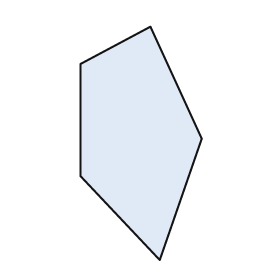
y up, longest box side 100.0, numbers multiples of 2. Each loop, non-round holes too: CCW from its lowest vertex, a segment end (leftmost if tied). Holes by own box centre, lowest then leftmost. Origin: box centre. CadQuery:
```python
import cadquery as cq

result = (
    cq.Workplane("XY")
    .moveTo(8.0, -50.0)
    .lineTo(26.0, 2.0)
    .lineTo(4.0, 50.0)
    .lineTo(-26.0, 34.0)
    .lineTo(-26.0, -14.0)
    .close()
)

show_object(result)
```